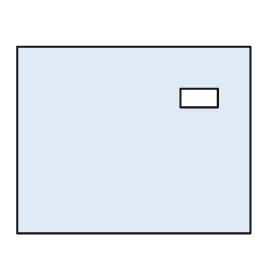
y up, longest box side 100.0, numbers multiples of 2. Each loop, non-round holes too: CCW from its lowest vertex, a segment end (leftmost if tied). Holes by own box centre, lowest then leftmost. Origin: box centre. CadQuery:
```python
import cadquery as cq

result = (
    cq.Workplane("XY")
    .moveTo(-50.0, -40.0)
    .lineTo(50.0, -40.0)
    .lineTo(50.0, 40.0)
    .lineTo(-50.0, 40.0)
    .close()
    .moveTo(20.0, 14.0)
    .lineTo(36.0, 14.0)
    .lineTo(36.0, 22.0)
    .lineTo(20.0, 22.0)
    .close()
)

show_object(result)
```